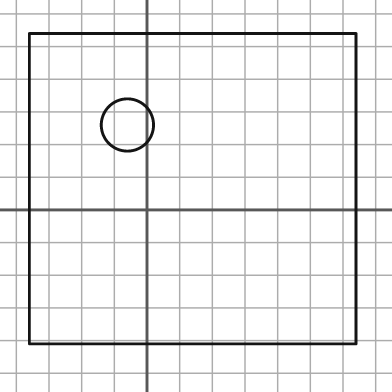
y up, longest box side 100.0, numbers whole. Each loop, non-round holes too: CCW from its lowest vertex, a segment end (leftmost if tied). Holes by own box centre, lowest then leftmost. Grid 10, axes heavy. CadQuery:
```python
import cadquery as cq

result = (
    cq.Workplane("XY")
    .moveTo(-36.0, -41.0)
    .lineTo(64.0, -41.0)
    .lineTo(64.0, 54.0)
    .lineTo(-36.0, 54.0)
    .close()
    .moveTo(-6.0, 26.0)
    .circle(8.0)
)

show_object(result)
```